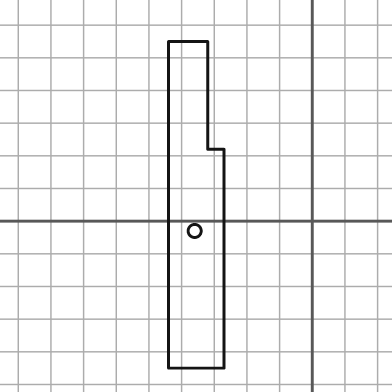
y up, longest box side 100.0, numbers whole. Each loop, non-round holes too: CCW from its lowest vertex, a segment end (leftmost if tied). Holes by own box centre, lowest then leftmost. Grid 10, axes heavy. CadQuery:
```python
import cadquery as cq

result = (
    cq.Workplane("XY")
    .moveTo(-44.0, -45.0)
    .lineTo(-27.0, -45.0)
    .lineTo(-27.0, 22.0)
    .lineTo(-32.0, 22.0)
    .lineTo(-32.0, 55.0)
    .lineTo(-44.0, 55.0)
    .close()
    .moveTo(-36.0, -3.0)
    .circle(2.0)
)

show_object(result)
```